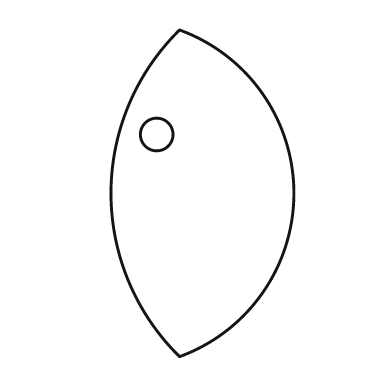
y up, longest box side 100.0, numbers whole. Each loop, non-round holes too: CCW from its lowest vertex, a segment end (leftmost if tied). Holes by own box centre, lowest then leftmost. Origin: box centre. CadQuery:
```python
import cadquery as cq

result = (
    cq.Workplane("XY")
    .moveTo(-7.0, -50.0)
    .threePointArc((28.0, 0.0), (-7.0, 50.0))
    .threePointArc((-28.0, 0.0), (-7.0, -50.0))
    .close()
    .moveTo(-14.0, 18.0)
    .circle(5.0)
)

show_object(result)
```